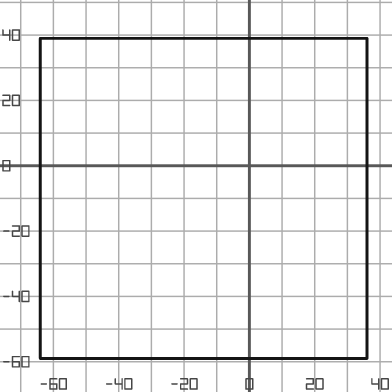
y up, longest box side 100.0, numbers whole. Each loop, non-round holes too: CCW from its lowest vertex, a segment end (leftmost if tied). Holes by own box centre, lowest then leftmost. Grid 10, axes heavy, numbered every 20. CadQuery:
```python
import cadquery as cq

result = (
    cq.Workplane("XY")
    .moveTo(-64.0, -59.0)
    .lineTo(36.0, -59.0)
    .lineTo(36.0, 39.0)
    .lineTo(-64.0, 39.0)
    .close()
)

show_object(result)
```